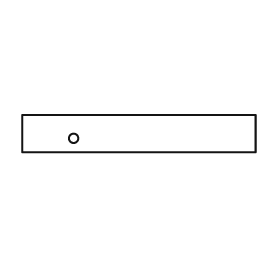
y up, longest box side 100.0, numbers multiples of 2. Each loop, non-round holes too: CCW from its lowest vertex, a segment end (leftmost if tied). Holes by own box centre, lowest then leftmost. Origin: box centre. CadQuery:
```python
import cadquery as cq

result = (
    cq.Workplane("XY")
    .moveTo(-50.0, -8.0)
    .lineTo(50.0, -8.0)
    .lineTo(50.0, 8.0)
    .lineTo(-50.0, 8.0)
    .close()
    .moveTo(-28.0, -2.0)
    .circle(2.0)
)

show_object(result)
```